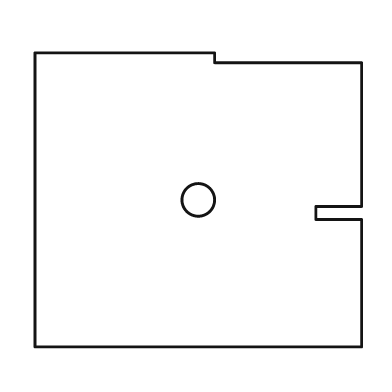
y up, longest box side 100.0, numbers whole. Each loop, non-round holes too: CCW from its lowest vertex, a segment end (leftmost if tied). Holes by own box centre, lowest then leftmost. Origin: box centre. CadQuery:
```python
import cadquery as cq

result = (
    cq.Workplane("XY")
    .moveTo(-50.0, -45.0)
    .lineTo(50.0, -45.0)
    .lineTo(50.0, -6.0)
    .lineTo(36.0, -6.0)
    .lineTo(36.0, -2.0)
    .lineTo(50.0, -2.0)
    .lineTo(50.0, 42.0)
    .lineTo(5.0, 42.0)
    .lineTo(5.0, 45.0)
    .lineTo(-50.0, 45.0)
    .close()
    .moveTo(0.0, 0.0)
    .circle(5.0)
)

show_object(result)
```